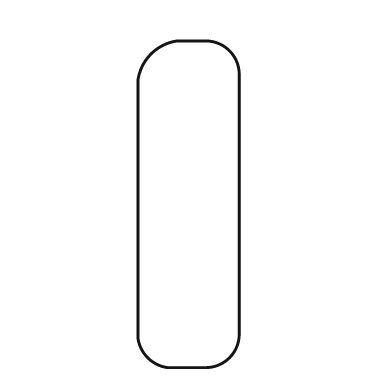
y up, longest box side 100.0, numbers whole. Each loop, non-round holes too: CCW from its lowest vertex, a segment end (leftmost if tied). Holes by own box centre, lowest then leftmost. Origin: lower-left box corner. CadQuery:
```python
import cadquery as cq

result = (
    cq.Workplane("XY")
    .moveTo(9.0, 0.0)
    .lineTo(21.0, 0.0)
    .threePointArc((28.0, 3.0), (31.0, 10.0))
    .lineTo(31.0, 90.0)
    .threePointArc((28.0, 97.0), (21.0, 100.0))
    .lineTo(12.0, 100.0)
    .threePointArc((4.0, 96.0), (0.0, 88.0))
    .lineTo(0.0, 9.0)
    .threePointArc((3.0, 3.0), (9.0, 0.0))
    .close()
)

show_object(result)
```